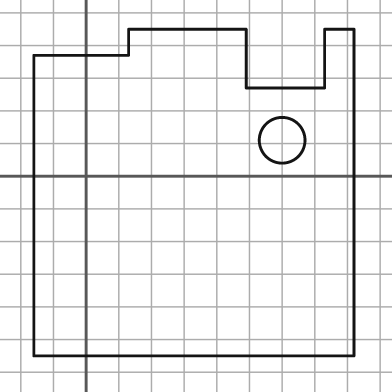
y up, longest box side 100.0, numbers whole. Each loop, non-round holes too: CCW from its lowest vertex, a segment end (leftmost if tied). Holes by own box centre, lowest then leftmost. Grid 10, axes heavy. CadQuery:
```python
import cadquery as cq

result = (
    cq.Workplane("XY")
    .moveTo(-16.0, -55.0)
    .lineTo(82.0, -55.0)
    .lineTo(82.0, 45.0)
    .lineTo(73.0, 45.0)
    .lineTo(73.0, 27.0)
    .lineTo(49.0, 27.0)
    .lineTo(49.0, 45.0)
    .lineTo(13.0, 45.0)
    .lineTo(13.0, 37.0)
    .lineTo(-16.0, 37.0)
    .close()
    .moveTo(60.0, 11.0)
    .circle(7.0)
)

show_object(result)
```